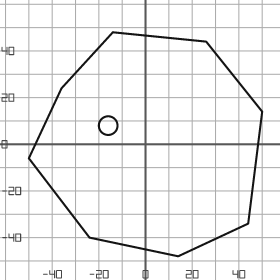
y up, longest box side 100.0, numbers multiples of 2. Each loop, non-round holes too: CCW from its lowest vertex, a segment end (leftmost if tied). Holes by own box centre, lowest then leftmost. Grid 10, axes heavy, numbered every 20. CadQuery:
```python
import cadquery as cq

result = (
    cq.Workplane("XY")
    .moveTo(14.0, -48.0)
    .lineTo(44.0, -34.0)
    .lineTo(50.0, 14.0)
    .lineTo(26.0, 44.0)
    .lineTo(-14.0, 48.0)
    .lineTo(-36.0, 24.0)
    .lineTo(-50.0, -6.0)
    .lineTo(-24.0, -40.0)
    .close()
    .moveTo(-16.0, 8.0)
    .circle(4.0)
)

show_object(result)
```